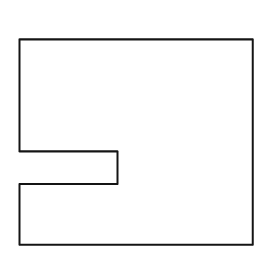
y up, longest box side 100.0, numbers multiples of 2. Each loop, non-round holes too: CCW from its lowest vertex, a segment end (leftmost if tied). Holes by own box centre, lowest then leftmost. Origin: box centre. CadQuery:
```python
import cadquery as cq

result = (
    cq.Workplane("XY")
    .moveTo(-50.0, -44.0)
    .lineTo(50.0, -44.0)
    .lineTo(50.0, 44.0)
    .lineTo(-50.0, 44.0)
    .lineTo(-50.0, -4.0)
    .lineTo(-8.0, -4.0)
    .lineTo(-8.0, -18.0)
    .lineTo(-50.0, -18.0)
    .close()
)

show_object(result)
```